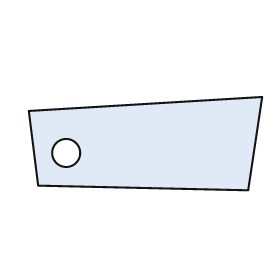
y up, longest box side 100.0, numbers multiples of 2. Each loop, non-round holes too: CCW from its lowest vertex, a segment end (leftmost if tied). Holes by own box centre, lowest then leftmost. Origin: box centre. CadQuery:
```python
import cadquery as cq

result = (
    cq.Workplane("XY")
    .moveTo(44.0, -20.0)
    .lineTo(50.0, 20.0)
    .lineTo(-50.0, 14.0)
    .lineTo(-46.0, -18.0)
    .close()
    .moveTo(-34.0, -4.0)
    .circle(6.0)
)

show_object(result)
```